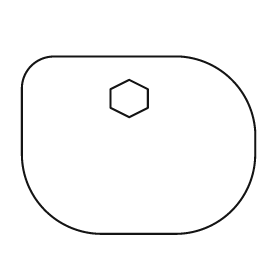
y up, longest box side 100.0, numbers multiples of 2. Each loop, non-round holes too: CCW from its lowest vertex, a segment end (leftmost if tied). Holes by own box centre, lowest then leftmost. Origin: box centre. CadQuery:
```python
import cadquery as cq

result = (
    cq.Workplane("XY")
    .moveTo(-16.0, -38.0)
    .lineTo(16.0, -38.0)
    .threePointArc((40.0, -28.0), (50.0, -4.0))
    .lineTo(50.0, 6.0)
    .threePointArc((40.0, 28.0), (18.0, 38.0))
    .lineTo(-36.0, 38.0)
    .threePointArc((-46.0, 34.0), (-50.0, 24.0))
    .lineTo(-50.0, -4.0)
    .threePointArc((-40.0, -28.0), (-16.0, -38.0))
    .close()
    .moveTo(-4.0, 12.0)
    .lineTo(4.0, 16.0)
    .lineTo(4.0, 24.0)
    .lineTo(-4.0, 28.0)
    .lineTo(-12.0, 24.0)
    .lineTo(-12.0, 16.0)
    .close()
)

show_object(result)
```